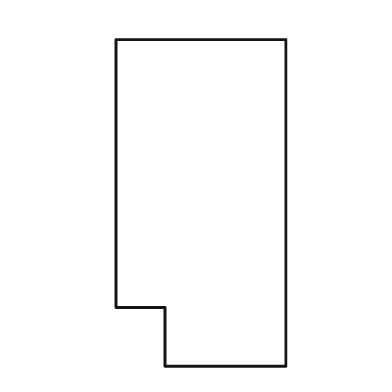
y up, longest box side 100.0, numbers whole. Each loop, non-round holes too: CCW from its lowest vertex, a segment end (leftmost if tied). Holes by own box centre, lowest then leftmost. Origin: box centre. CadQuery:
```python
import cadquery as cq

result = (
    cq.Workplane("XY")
    .moveTo(-11.0, -50.0)
    .lineTo(26.0, -50.0)
    .lineTo(26.0, 50.0)
    .lineTo(-26.0, 50.0)
    .lineTo(-26.0, -32.0)
    .lineTo(-11.0, -32.0)
    .close()
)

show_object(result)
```